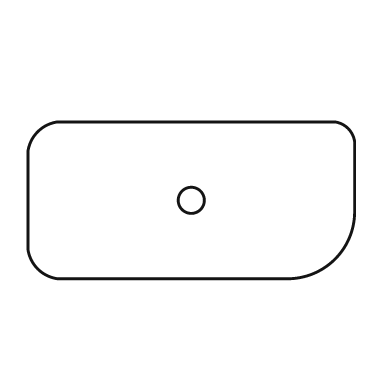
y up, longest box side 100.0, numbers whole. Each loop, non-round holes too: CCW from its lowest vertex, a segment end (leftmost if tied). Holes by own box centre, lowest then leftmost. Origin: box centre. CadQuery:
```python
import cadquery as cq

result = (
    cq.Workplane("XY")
    .moveTo(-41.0, -24.0)
    .lineTo(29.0, -24.0)
    .threePointArc((44.0, -18.0), (50.0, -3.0))
    .lineTo(50.0, 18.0)
    .threePointArc((48.0, 22.0), (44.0, 24.0))
    .lineTo(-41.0, 24.0)
    .threePointArc((-47.0, 21.0), (-50.0, 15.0))
    .lineTo(-50.0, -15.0)
    .threePointArc((-47.0, -21.0), (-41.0, -24.0))
    .close()
    .moveTo(0.0, 0.0)
    .circle(4.0)
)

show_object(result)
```